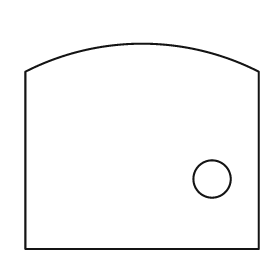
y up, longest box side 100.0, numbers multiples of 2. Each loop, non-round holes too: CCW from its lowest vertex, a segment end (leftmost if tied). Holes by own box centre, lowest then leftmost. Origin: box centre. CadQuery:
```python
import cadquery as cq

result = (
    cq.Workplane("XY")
    .moveTo(-50.0, -44.0)
    .lineTo(50.0, -44.0)
    .lineTo(50.0, 32.0)
    .threePointArc((0.0, 44.0), (-50.0, 32.0))
    .close()
    .moveTo(30.0, -14.0)
    .circle(8.0)
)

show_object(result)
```